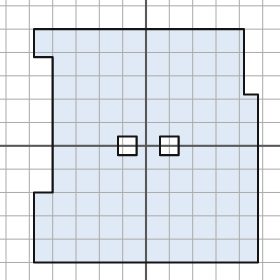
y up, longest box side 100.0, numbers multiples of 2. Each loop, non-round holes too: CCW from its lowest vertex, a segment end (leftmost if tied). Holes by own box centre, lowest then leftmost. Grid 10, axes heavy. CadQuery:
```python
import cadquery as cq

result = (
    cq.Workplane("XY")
    .moveTo(-48.0, -50.0)
    .lineTo(48.0, -50.0)
    .lineTo(48.0, 22.0)
    .lineTo(42.0, 22.0)
    .lineTo(42.0, 50.0)
    .lineTo(-48.0, 50.0)
    .lineTo(-48.0, 38.0)
    .lineTo(-40.0, 38.0)
    .lineTo(-40.0, -20.0)
    .lineTo(-48.0, -20.0)
    .close()
    .moveTo(-12.0, -4.0)
    .lineTo(-4.0, -4.0)
    .lineTo(-4.0, 4.0)
    .lineTo(-12.0, 4.0)
    .close()
    .moveTo(6.0, -4.0)
    .lineTo(14.0, -4.0)
    .lineTo(14.0, 4.0)
    .lineTo(6.0, 4.0)
    .close()
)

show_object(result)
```